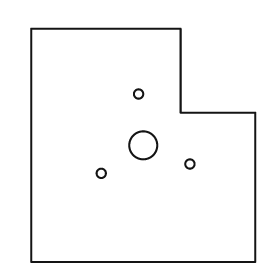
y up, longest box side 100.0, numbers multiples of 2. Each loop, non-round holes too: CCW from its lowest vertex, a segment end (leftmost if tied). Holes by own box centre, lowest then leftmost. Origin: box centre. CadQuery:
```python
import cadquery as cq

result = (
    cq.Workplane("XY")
    .moveTo(-48.0, -50.0)
    .lineTo(48.0, -50.0)
    .lineTo(48.0, 14.0)
    .lineTo(16.0, 14.0)
    .lineTo(16.0, 50.0)
    .lineTo(-48.0, 50.0)
    .close()
    .moveTo(-18.0, -12.0)
    .circle(2.0)
    .moveTo(20.0, -8.0)
    .circle(2.0)
    .moveTo(0.0, 0.0)
    .circle(6.0)
    .moveTo(-2.0, 22.0)
    .circle(2.0)
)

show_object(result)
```